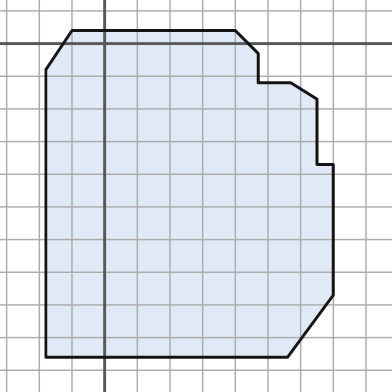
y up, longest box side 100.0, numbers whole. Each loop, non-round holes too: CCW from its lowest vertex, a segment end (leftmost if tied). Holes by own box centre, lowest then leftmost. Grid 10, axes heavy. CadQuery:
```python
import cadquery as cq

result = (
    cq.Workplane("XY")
    .moveTo(-18.0, -96.0)
    .lineTo(56.0, -96.0)
    .lineTo(70.0, -77.0)
    .lineTo(70.0, -37.0)
    .lineTo(65.0, -37.0)
    .lineTo(65.0, -17.0)
    .lineTo(57.0, -12.0)
    .lineTo(47.0, -12.0)
    .lineTo(47.0, -3.0)
    .lineTo(40.0, 4.0)
    .lineTo(-10.0, 4.0)
    .lineTo(-18.0, -8.0)
    .close()
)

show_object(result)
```